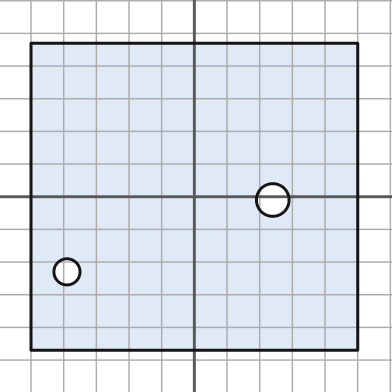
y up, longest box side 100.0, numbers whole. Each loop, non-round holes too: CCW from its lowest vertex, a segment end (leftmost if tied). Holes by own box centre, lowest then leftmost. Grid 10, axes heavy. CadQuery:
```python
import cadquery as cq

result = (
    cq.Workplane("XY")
    .moveTo(-50.0, -47.0)
    .lineTo(50.0, -47.0)
    .lineTo(50.0, 47.0)
    .lineTo(-50.0, 47.0)
    .close()
    .moveTo(-39.0, -23.0)
    .circle(4.0)
    .moveTo(24.0, -1.0)
    .circle(5.0)
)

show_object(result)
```